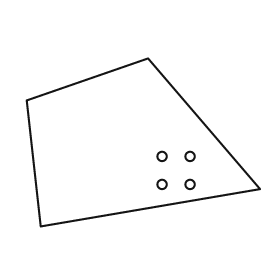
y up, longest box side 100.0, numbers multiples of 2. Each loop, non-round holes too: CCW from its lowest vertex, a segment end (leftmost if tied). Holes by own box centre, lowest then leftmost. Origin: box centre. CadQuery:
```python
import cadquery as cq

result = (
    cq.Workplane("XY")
    .moveTo(-44.0, -36.0)
    .lineTo(50.0, -20.0)
    .lineTo(2.0, 36.0)
    .lineTo(-50.0, 18.0)
    .close()
    .moveTo(8.0, -18.0)
    .circle(2.0)
    .moveTo(20.0, -18.0)
    .circle(2.0)
    .moveTo(8.0, -6.0)
    .circle(2.0)
    .moveTo(20.0, -6.0)
    .circle(2.0)
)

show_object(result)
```